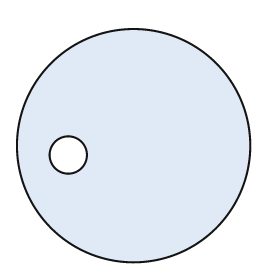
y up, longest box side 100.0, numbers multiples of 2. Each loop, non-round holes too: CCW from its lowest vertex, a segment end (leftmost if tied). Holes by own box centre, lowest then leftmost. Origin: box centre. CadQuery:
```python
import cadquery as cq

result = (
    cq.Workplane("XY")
    .moveTo(0.0, 0.0)
    .circle(50.0)
    .moveTo(-28.0, -4.0)
    .circle(8.0)
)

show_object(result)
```